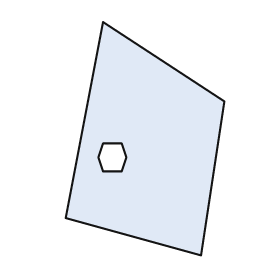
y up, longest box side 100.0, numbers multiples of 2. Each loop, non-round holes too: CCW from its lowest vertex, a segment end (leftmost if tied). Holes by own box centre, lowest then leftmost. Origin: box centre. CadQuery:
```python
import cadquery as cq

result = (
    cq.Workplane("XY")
    .moveTo(24.0, -50.0)
    .lineTo(34.0, 16.0)
    .lineTo(-18.0, 50.0)
    .lineTo(-34.0, -34.0)
    .close()
    .moveTo(-18.0, -14.0)
    .lineTo(-10.0, -14.0)
    .lineTo(-8.0, -8.0)
    .lineTo(-10.0, -2.0)
    .lineTo(-18.0, -2.0)
    .lineTo(-20.0, -8.0)
    .close()
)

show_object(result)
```